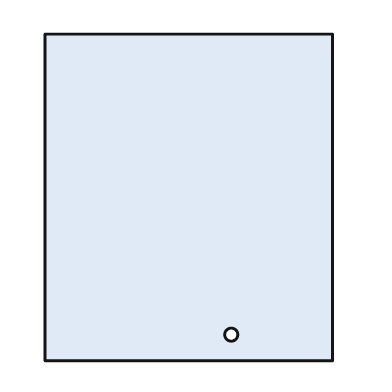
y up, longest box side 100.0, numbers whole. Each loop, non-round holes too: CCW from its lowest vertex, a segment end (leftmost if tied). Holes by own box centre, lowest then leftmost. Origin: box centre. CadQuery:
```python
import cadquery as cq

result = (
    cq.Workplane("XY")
    .moveTo(-44.0, -50.0)
    .lineTo(44.0, -50.0)
    .lineTo(44.0, 50.0)
    .lineTo(-44.0, 50.0)
    .close()
    .moveTo(13.0, -42.0)
    .circle(2.0)
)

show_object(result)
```